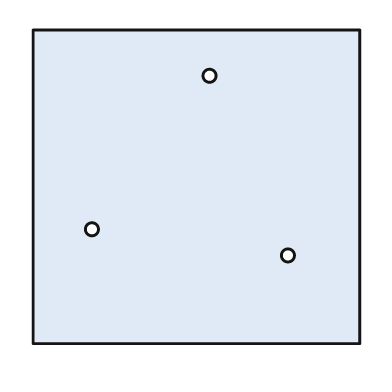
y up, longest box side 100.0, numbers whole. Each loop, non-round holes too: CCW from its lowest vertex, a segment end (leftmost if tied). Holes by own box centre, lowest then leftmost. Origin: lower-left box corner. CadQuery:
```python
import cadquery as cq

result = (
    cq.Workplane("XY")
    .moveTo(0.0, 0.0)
    .lineTo(100.0, 0.0)
    .lineTo(100.0, 96.0)
    .lineTo(0.0, 96.0)
    .close()
    .moveTo(78.0, 27.0)
    .circle(2.0)
    .moveTo(18.0, 35.0)
    .circle(2.0)
    .moveTo(54.0, 82.0)
    .circle(2.0)
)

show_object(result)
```